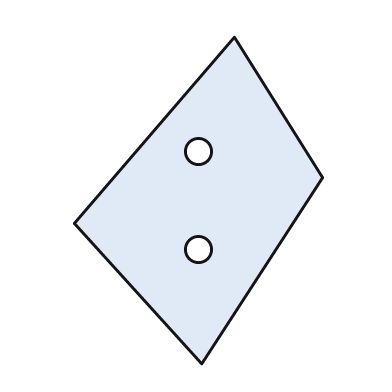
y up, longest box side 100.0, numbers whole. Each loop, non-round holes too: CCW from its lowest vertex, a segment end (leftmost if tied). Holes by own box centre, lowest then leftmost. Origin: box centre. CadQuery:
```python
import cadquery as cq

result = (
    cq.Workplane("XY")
    .moveTo(1.0, -50.0)
    .lineTo(38.0, 7.0)
    .lineTo(11.0, 50.0)
    .lineTo(-38.0, -7.0)
    .close()
    .moveTo(0.0, -15.0)
    .circle(4.0)
    .moveTo(0.0, 15.0)
    .circle(4.0)
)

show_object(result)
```